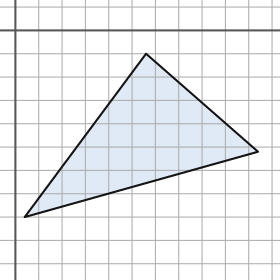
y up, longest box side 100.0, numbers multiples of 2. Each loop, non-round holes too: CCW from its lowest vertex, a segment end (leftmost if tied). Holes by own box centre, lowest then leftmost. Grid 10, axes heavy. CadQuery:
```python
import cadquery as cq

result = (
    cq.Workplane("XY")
    .moveTo(4.0, -80.0)
    .lineTo(104.0, -52.0)
    .lineTo(56.0, -10.0)
    .close()
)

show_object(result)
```